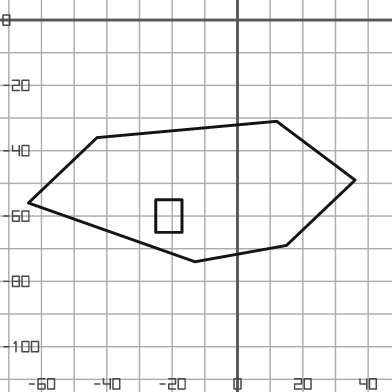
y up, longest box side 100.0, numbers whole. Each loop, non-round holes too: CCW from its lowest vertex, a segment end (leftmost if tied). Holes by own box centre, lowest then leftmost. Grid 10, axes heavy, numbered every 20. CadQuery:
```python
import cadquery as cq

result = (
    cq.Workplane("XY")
    .moveTo(-13.0, -74.0)
    .lineTo(15.0, -69.0)
    .lineTo(36.0, -49.0)
    .lineTo(12.0, -31.0)
    .lineTo(-43.0, -36.0)
    .lineTo(-64.0, -56.0)
    .close()
    .moveTo(-25.0, -65.0)
    .lineTo(-17.0, -65.0)
    .lineTo(-17.0, -55.0)
    .lineTo(-25.0, -55.0)
    .close()
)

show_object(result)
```